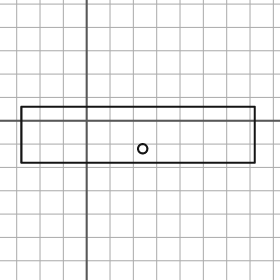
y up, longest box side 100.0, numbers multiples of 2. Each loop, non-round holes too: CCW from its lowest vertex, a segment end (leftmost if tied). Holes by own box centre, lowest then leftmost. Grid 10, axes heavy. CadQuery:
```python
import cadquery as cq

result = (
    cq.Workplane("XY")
    .moveTo(-28.0, -18.0)
    .lineTo(72.0, -18.0)
    .lineTo(72.0, 6.0)
    .lineTo(-28.0, 6.0)
    .close()
    .moveTo(24.0, -12.0)
    .circle(2.0)
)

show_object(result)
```